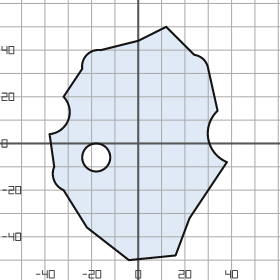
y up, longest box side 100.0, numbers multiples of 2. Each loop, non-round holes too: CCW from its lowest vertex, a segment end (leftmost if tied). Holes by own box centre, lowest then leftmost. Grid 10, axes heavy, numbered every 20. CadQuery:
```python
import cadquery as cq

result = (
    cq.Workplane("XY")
    .moveTo(-4.0, -50.0)
    .lineTo(16.0, -48.0)
    .lineTo(22.0, -32.0)
    .lineTo(38.0, -8.0)
    .threePointArc((30.0, 2.0), (34.0, 14.0))
    .lineTo(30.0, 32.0)
    .threePointArc((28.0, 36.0), (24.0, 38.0))
    .lineTo(12.0, 50.0)
    .lineTo(0.0, 44.0)
    .lineTo(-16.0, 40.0)
    .threePointArc((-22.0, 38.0), (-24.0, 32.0))
    .lineTo(-32.0, 20.0)
    .threePointArc((-30.0, 10.0), (-38.0, 4.0))
    .lineTo(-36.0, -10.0)
    .threePointArc((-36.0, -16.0), (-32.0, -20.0))
    .lineTo(-22.0, -36.0)
    .close()
    .moveTo(-18.0, -6.0)
    .circle(6.0)
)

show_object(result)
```